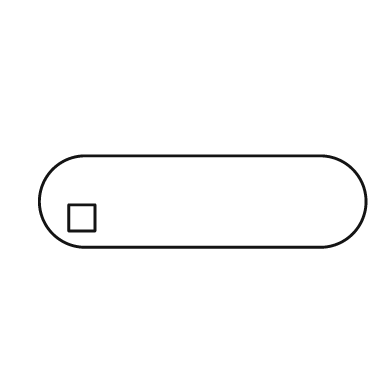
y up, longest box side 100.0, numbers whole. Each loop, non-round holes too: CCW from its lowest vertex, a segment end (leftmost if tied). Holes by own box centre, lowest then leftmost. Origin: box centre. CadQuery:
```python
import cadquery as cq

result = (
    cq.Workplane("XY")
    .moveTo(-36.0, -14.0)
    .lineTo(36.0, -14.0)
    .threePointArc((50.0, 0.0), (36.0, 14.0))
    .lineTo(-36.0, 14.0)
    .threePointArc((-50.0, 0.0), (-36.0, -14.0))
    .close()
    .moveTo(-41.0, -9.0)
    .lineTo(-33.0, -9.0)
    .lineTo(-33.0, -1.0)
    .lineTo(-41.0, -1.0)
    .close()
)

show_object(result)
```